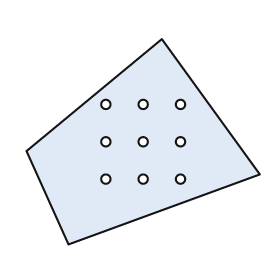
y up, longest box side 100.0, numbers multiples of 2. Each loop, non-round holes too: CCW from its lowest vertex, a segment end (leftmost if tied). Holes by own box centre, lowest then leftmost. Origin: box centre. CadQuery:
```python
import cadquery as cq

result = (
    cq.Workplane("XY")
    .moveTo(-32.0, -44.0)
    .lineTo(50.0, -14.0)
    .lineTo(8.0, 44.0)
    .lineTo(-50.0, -4.0)
    .close()
    .moveTo(-16.0, -16.0)
    .circle(2.0)
    .moveTo(0.0, -16.0)
    .circle(2.0)
    .moveTo(16.0, -16.0)
    .circle(2.0)
    .moveTo(-16.0, 0.0)
    .circle(2.0)
    .moveTo(0.0, 0.0)
    .circle(2.0)
    .moveTo(16.0, 0.0)
    .circle(2.0)
    .moveTo(-16.0, 16.0)
    .circle(2.0)
    .moveTo(0.0, 16.0)
    .circle(2.0)
    .moveTo(16.0, 16.0)
    .circle(2.0)
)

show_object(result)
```